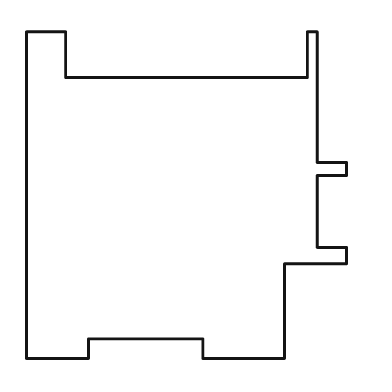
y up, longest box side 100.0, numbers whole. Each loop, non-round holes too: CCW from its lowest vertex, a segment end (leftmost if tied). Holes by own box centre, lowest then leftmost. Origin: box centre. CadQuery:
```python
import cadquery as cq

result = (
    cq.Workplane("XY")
    .moveTo(-49.0, -50.0)
    .lineTo(-30.0, -50.0)
    .lineTo(-30.0, -44.0)
    .lineTo(5.0, -44.0)
    .lineTo(5.0, -50.0)
    .lineTo(30.0, -50.0)
    .lineTo(30.0, -21.0)
    .lineTo(49.0, -21.0)
    .lineTo(49.0, -16.0)
    .lineTo(40.0, -16.0)
    .lineTo(40.0, 6.0)
    .lineTo(49.0, 6.0)
    .lineTo(49.0, 10.0)
    .lineTo(40.0, 10.0)
    .lineTo(40.0, 50.0)
    .lineTo(37.0, 50.0)
    .lineTo(37.0, 36.0)
    .lineTo(-37.0, 36.0)
    .lineTo(-37.0, 50.0)
    .lineTo(-49.0, 50.0)
    .close()
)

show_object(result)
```